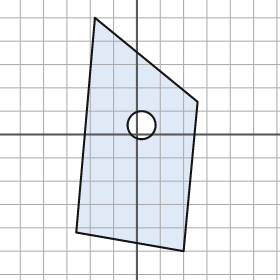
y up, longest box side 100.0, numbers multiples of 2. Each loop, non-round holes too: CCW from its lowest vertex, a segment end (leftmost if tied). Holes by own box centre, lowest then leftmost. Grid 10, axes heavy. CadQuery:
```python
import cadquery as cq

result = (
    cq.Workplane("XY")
    .moveTo(20.0, -50.0)
    .lineTo(26.0, 14.0)
    .lineTo(-18.0, 50.0)
    .lineTo(-26.0, -42.0)
    .close()
    .moveTo(2.0, 4.0)
    .circle(6.0)
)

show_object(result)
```